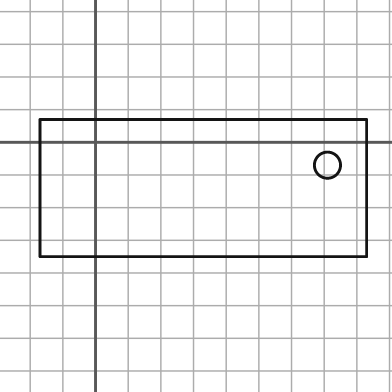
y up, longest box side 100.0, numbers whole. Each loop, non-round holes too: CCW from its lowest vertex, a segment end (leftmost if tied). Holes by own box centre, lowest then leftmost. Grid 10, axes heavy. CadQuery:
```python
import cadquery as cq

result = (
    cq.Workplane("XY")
    .moveTo(-17.0, -35.0)
    .lineTo(83.0, -35.0)
    .lineTo(83.0, 7.0)
    .lineTo(-17.0, 7.0)
    .close()
    .moveTo(71.0, -7.0)
    .circle(4.0)
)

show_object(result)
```